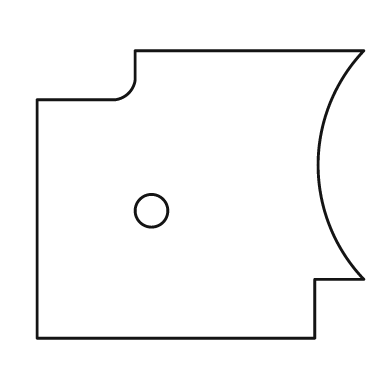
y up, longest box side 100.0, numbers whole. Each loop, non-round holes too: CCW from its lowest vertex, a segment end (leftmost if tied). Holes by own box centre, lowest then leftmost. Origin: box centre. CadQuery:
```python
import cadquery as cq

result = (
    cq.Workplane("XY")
    .moveTo(-50.0, -44.0)
    .lineTo(35.0, -44.0)
    .lineTo(35.0, -26.0)
    .lineTo(50.0, -26.0)
    .threePointArc((36.0, 9.0), (50.0, 44.0))
    .lineTo(-20.0, 44.0)
    .lineTo(-20.0, 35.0)
    .threePointArc((-22.0, 31.0), (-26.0, 29.0))
    .lineTo(-50.0, 29.0)
    .close()
    .moveTo(-15.0, -5.0)
    .circle(5.0)
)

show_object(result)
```